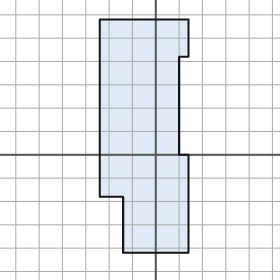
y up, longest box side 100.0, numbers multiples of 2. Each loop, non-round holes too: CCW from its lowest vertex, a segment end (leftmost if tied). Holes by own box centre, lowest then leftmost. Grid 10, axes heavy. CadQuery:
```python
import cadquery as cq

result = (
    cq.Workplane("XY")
    .moveTo(-14.0, -42.0)
    .lineTo(14.0, -42.0)
    .lineTo(14.0, 0.0)
    .lineTo(10.0, 0.0)
    .lineTo(10.0, 42.0)
    .lineTo(14.0, 42.0)
    .lineTo(14.0, 58.0)
    .lineTo(-24.0, 58.0)
    .lineTo(-24.0, -18.0)
    .lineTo(-14.0, -18.0)
    .close()
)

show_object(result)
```